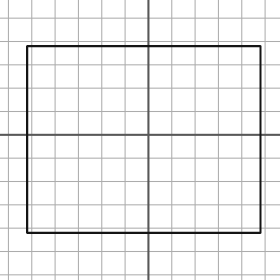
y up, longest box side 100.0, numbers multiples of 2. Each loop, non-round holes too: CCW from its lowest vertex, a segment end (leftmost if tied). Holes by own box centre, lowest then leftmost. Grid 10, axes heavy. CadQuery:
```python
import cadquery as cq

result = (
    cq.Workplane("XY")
    .moveTo(-52.0, -42.0)
    .lineTo(48.0, -42.0)
    .lineTo(48.0, 38.0)
    .lineTo(-52.0, 38.0)
    .close()
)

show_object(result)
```